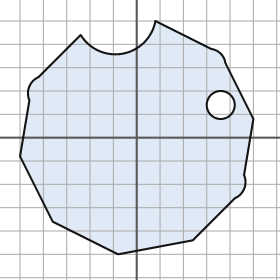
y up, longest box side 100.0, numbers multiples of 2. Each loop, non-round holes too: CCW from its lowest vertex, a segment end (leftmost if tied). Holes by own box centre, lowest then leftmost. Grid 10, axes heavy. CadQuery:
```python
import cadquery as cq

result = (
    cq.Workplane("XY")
    .moveTo(-8.0, -50.0)
    .lineTo(24.0, -44.0)
    .lineTo(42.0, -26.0)
    .threePointArc((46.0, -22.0), (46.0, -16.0))
    .lineTo(50.0, 8.0)
    .lineTo(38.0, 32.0)
    .threePointArc((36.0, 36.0), (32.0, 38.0))
    .lineTo(8.0, 50.0)
    .threePointArc((-6.0, 36.0), (-24.0, 44.0))
    .lineTo(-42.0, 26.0)
    .threePointArc((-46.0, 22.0), (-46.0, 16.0))
    .lineTo(-50.0, -8.0)
    .lineTo(-36.0, -36.0)
    .close()
    .moveTo(36.0, 14.0)
    .circle(6.0)
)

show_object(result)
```